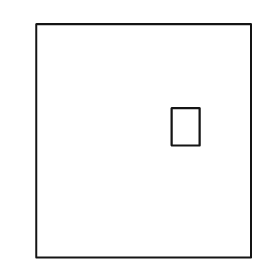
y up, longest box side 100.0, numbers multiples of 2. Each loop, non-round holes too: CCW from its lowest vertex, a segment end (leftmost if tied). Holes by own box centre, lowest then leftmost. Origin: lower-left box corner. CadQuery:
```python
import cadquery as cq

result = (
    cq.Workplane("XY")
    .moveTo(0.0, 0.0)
    .lineTo(92.0, 0.0)
    .lineTo(92.0, 100.0)
    .lineTo(0.0, 100.0)
    .close()
    .moveTo(58.0, 48.0)
    .lineTo(70.0, 48.0)
    .lineTo(70.0, 64.0)
    .lineTo(58.0, 64.0)
    .close()
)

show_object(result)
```